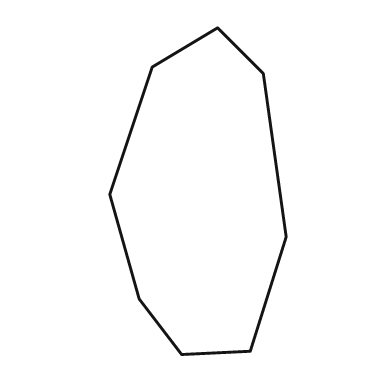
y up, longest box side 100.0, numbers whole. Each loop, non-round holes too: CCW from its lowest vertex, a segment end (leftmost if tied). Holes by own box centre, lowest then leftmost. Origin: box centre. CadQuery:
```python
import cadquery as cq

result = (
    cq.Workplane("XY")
    .moveTo(-5.0, -50.0)
    .lineTo(16.0, -49.0)
    .lineTo(27.0, -14.0)
    .lineTo(20.0, 36.0)
    .lineTo(6.0, 50.0)
    .lineTo(-14.0, 38.0)
    .lineTo(-27.0, -1.0)
    .lineTo(-18.0, -33.0)
    .close()
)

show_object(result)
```